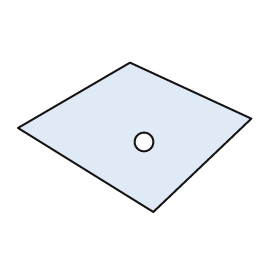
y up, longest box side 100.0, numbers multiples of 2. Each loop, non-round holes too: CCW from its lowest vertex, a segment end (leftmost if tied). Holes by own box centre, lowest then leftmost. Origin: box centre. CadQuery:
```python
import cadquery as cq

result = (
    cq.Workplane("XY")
    .moveTo(8.0, -32.0)
    .lineTo(50.0, 8.0)
    .lineTo(-2.0, 32.0)
    .lineTo(-50.0, 4.0)
    .close()
    .moveTo(4.0, -2.0)
    .circle(4.0)
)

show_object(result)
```